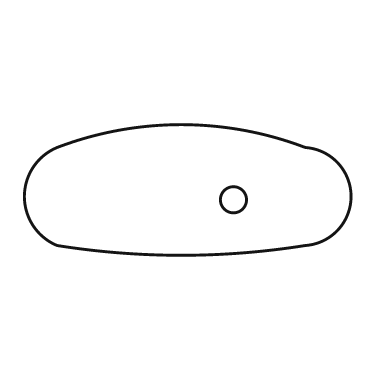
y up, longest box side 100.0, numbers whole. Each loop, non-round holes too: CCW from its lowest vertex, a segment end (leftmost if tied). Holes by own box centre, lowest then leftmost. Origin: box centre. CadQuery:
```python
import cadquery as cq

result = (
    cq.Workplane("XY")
    .moveTo(-40.0, -17.0)
    .threePointArc((-2.0, -20.0), (36.0, -17.0))
    .threePointArc((50.0, -2.0), (36.0, 13.0))
    .threePointArc((-2.0, 20.0), (-40.0, 13.0))
    .threePointArc((-50.0, -2.0), (-40.0, -17.0))
    .close()
    .moveTo(14.0, -3.0)
    .circle(4.0)
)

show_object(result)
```